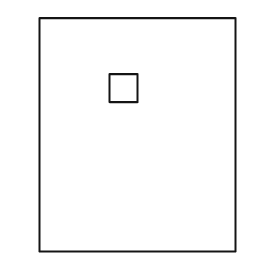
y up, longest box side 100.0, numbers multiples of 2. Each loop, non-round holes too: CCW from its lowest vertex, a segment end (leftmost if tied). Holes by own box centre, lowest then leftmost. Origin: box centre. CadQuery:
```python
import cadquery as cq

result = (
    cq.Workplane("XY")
    .moveTo(-42.0, -50.0)
    .lineTo(42.0, -50.0)
    .lineTo(42.0, 50.0)
    .lineTo(-42.0, 50.0)
    .close()
    .moveTo(-12.0, 14.0)
    .lineTo(0.0, 14.0)
    .lineTo(0.0, 26.0)
    .lineTo(-12.0, 26.0)
    .close()
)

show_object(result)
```